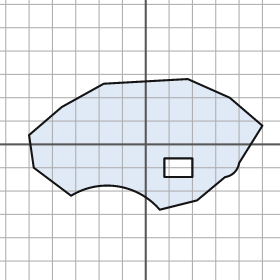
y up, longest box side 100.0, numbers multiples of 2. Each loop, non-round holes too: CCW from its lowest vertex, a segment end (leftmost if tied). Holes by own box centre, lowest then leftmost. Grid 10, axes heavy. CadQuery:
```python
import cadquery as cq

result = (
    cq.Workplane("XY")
    .moveTo(6.0, -28.0)
    .lineTo(22.0, -24.0)
    .lineTo(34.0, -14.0)
    .threePointArc((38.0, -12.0), (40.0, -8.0))
    .lineTo(50.0, 8.0)
    .lineTo(36.0, 20.0)
    .lineTo(18.0, 28.0)
    .lineTo(-18.0, 26.0)
    .lineTo(-36.0, 16.0)
    .lineTo(-50.0, 4.0)
    .lineTo(-48.0, -10.0)
    .lineTo(-32.0, -22.0)
    .threePointArc((-12.0, -18.0), (6.0, -28.0))
    .close()
    .moveTo(8.0, -14.0)
    .lineTo(20.0, -14.0)
    .lineTo(20.0, -6.0)
    .lineTo(8.0, -6.0)
    .close()
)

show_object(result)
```